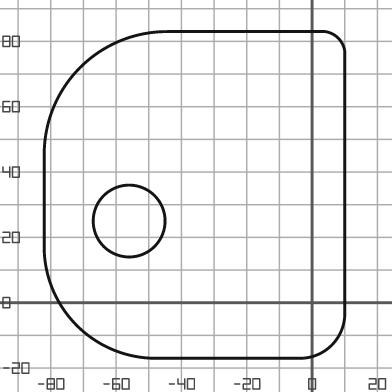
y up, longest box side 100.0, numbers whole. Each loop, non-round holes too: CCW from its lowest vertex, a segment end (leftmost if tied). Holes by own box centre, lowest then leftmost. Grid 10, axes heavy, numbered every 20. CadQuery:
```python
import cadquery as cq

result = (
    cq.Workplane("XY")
    .moveTo(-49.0, -17.0)
    .lineTo(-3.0, -17.0)
    .threePointArc((6.0, -13.0), (10.0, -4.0))
    .lineTo(10.0, 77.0)
    .threePointArc((8.0, 81.0), (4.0, 83.0))
    .lineTo(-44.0, 83.0)
    .threePointArc((-71.0, 72.0), (-82.0, 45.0))
    .lineTo(-82.0, 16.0)
    .threePointArc((-72.0, -7.0), (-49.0, -17.0))
    .close()
    .moveTo(-56.0, 25.0)
    .circle(11.0)
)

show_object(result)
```